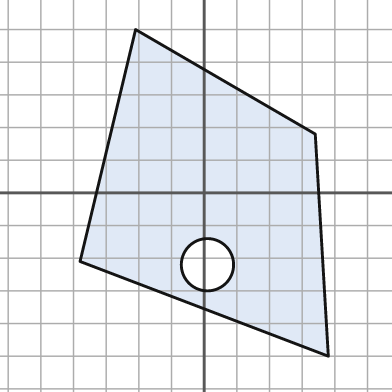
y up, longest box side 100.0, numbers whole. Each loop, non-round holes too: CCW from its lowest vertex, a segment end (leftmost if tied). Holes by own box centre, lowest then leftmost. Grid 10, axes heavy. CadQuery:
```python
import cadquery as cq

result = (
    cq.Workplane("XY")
    .moveTo(38.0, -50.0)
    .lineTo(34.0, 18.0)
    .lineTo(-21.0, 50.0)
    .lineTo(-38.0, -21.0)
    .close()
    .moveTo(1.0, -22.0)
    .circle(8.0)
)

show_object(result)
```